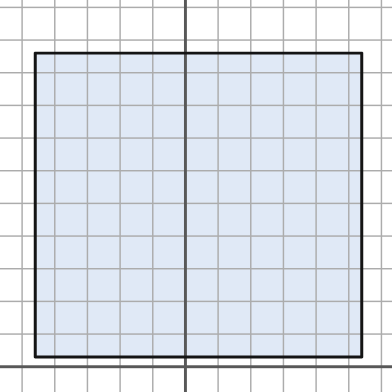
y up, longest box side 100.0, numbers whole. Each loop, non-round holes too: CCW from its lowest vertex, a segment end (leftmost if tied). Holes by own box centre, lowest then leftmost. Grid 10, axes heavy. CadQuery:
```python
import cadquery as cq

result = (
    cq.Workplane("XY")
    .moveTo(-46.0, 3.0)
    .lineTo(54.0, 3.0)
    .lineTo(54.0, 96.0)
    .lineTo(-46.0, 96.0)
    .close()
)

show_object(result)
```